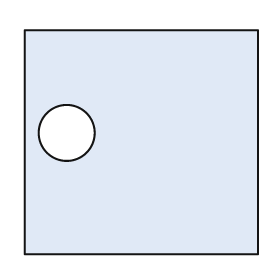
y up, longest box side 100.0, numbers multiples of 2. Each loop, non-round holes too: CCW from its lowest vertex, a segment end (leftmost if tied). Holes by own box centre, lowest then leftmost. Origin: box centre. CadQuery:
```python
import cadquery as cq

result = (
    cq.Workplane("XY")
    .moveTo(-50.0, -48.0)
    .lineTo(50.0, -48.0)
    .lineTo(50.0, 48.0)
    .lineTo(-50.0, 48.0)
    .close()
    .moveTo(-32.0, 4.0)
    .circle(12.0)
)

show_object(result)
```